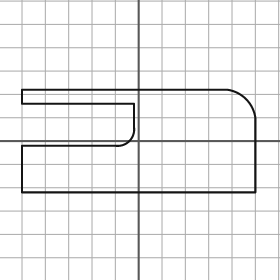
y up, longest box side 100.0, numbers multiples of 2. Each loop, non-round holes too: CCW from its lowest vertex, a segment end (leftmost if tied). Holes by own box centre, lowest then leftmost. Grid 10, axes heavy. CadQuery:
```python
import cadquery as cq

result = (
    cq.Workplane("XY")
    .moveTo(-50.0, -22.0)
    .lineTo(50.0, -22.0)
    .lineTo(50.0, 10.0)
    .threePointArc((46.0, 18.0), (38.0, 22.0))
    .lineTo(-50.0, 22.0)
    .lineTo(-50.0, 16.0)
    .lineTo(-2.0, 16.0)
    .lineTo(-2.0, 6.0)
    .threePointArc((-4.0, 0.0), (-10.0, -2.0))
    .lineTo(-50.0, -2.0)
    .close()
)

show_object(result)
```